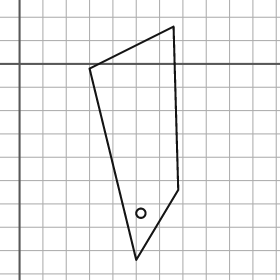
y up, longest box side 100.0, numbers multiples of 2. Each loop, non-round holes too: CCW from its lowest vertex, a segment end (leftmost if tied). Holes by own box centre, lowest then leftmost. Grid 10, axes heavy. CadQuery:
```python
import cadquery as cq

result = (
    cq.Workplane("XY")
    .moveTo(50.0, -84.0)
    .lineTo(68.0, -54.0)
    .lineTo(66.0, 16.0)
    .lineTo(30.0, -2.0)
    .close()
    .moveTo(52.0, -64.0)
    .circle(2.0)
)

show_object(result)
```